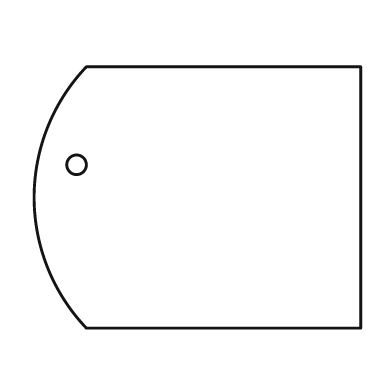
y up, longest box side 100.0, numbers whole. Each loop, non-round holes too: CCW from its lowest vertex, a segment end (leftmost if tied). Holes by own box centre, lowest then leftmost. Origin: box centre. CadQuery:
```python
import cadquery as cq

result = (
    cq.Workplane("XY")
    .moveTo(-34.0, -40.0)
    .lineTo(50.0, -40.0)
    .lineTo(50.0, 40.0)
    .lineTo(-34.0, 40.0)
    .threePointArc((-50.0, 0.0), (-34.0, -40.0))
    .close()
    .moveTo(-37.0, 10.0)
    .circle(3.0)
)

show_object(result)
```